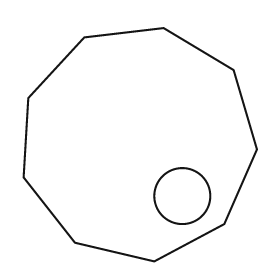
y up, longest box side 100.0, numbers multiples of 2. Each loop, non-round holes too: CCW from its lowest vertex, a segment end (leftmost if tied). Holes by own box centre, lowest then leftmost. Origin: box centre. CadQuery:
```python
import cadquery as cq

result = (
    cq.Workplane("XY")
    .moveTo(6.0, -50.0)
    .lineTo(36.0, -34.0)
    .lineTo(50.0, -2.0)
    .lineTo(40.0, 32.0)
    .lineTo(10.0, 50.0)
    .lineTo(-24.0, 46.0)
    .lineTo(-48.0, 20.0)
    .lineTo(-50.0, -14.0)
    .lineTo(-28.0, -42.0)
    .close()
    .moveTo(18.0, -22.0)
    .circle(12.0)
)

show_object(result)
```